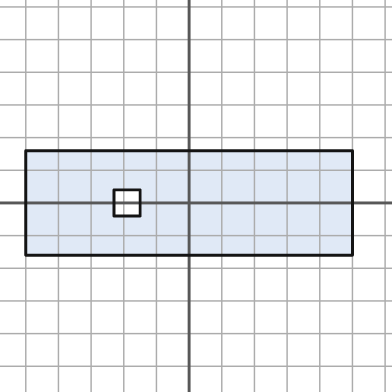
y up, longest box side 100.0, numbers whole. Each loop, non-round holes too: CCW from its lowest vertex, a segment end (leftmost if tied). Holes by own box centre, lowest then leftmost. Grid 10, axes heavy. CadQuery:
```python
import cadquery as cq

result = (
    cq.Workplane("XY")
    .moveTo(-50.0, -16.0)
    .lineTo(50.0, -16.0)
    .lineTo(50.0, 16.0)
    .lineTo(-50.0, 16.0)
    .close()
    .moveTo(-23.0, -4.0)
    .lineTo(-15.0, -4.0)
    .lineTo(-15.0, 4.0)
    .lineTo(-23.0, 4.0)
    .close()
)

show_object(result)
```